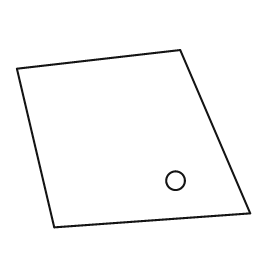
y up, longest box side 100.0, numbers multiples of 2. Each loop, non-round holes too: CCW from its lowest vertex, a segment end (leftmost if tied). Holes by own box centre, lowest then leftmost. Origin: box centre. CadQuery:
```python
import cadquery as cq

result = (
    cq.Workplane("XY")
    .moveTo(-34.0, -38.0)
    .lineTo(50.0, -32.0)
    .lineTo(20.0, 38.0)
    .lineTo(-50.0, 30.0)
    .close()
    .moveTo(18.0, -18.0)
    .circle(4.0)
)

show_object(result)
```